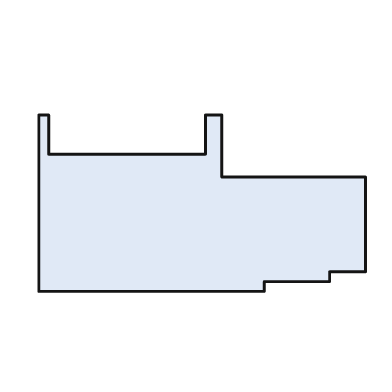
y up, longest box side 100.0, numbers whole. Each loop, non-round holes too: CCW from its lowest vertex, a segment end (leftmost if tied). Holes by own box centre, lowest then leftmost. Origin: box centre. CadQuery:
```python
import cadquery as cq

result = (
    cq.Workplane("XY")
    .moveTo(-50.0, -27.0)
    .lineTo(19.0, -27.0)
    .lineTo(19.0, -24.0)
    .lineTo(39.0, -24.0)
    .lineTo(39.0, -21.0)
    .lineTo(50.0, -21.0)
    .lineTo(50.0, 8.0)
    .lineTo(6.0, 8.0)
    .lineTo(6.0, 27.0)
    .lineTo(1.0, 27.0)
    .lineTo(1.0, 15.0)
    .lineTo(-47.0, 15.0)
    .lineTo(-47.0, 27.0)
    .lineTo(-50.0, 27.0)
    .close()
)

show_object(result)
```